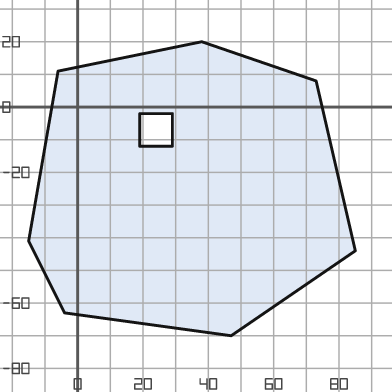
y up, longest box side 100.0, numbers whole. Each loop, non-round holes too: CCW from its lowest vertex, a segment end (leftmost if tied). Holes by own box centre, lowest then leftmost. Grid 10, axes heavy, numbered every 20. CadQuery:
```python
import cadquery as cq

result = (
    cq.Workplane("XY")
    .moveTo(47.0, -70.0)
    .lineTo(85.0, -44.0)
    .lineTo(73.0, 8.0)
    .lineTo(38.0, 20.0)
    .lineTo(-6.0, 11.0)
    .lineTo(-15.0, -41.0)
    .lineTo(-4.0, -63.0)
    .close()
    .moveTo(19.0, -12.0)
    .lineTo(29.0, -12.0)
    .lineTo(29.0, -2.0)
    .lineTo(19.0, -2.0)
    .close()
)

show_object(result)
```